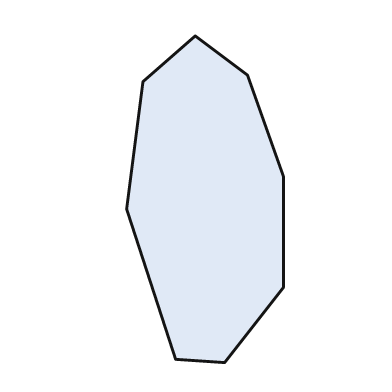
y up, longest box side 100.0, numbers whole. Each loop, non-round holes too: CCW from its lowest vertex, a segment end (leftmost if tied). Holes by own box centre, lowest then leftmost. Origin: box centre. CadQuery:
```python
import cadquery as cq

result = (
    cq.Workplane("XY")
    .moveTo(6.0, -50.0)
    .lineTo(24.0, -27.0)
    .lineTo(24.0, 7.0)
    .lineTo(13.0, 38.0)
    .lineTo(-3.0, 50.0)
    .lineTo(-19.0, 36.0)
    .lineTo(-24.0, -3.0)
    .lineTo(-9.0, -49.0)
    .close()
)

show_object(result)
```